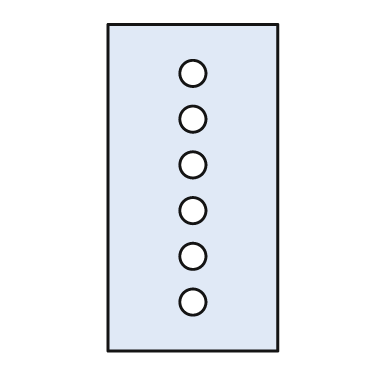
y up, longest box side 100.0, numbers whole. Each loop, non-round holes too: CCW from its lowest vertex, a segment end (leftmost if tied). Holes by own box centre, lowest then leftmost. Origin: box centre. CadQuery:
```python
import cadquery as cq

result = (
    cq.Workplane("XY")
    .moveTo(-26.0, -50.0)
    .lineTo(26.0, -50.0)
    .lineTo(26.0, 50.0)
    .lineTo(-26.0, 50.0)
    .close()
    .moveTo(0.0, -35.0)
    .circle(4.0)
    .moveTo(0.0, -21.0)
    .circle(4.0)
    .moveTo(0.0, -7.0)
    .circle(4.0)
    .moveTo(0.0, 7.0)
    .circle(4.0)
    .moveTo(0.0, 21.0)
    .circle(4.0)
    .moveTo(0.0, 35.0)
    .circle(4.0)
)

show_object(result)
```